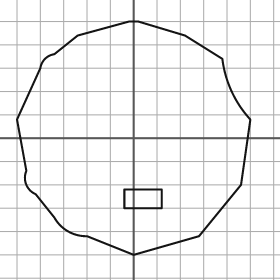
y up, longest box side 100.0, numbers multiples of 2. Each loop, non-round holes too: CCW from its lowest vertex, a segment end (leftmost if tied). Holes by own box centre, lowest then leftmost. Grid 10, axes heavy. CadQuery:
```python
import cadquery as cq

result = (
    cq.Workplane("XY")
    .moveTo(0.0, -50.0)
    .lineTo(28.0, -42.0)
    .lineTo(46.0, -20.0)
    .lineTo(50.0, 8.0)
    .threePointArc((42.0, 20.0), (38.0, 34.0))
    .lineTo(22.0, 44.0)
    .lineTo(2.0, 50.0)
    .lineTo(-2.0, 50.0)
    .lineTo(-24.0, 44.0)
    .lineTo(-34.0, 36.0)
    .threePointArc((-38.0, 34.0), (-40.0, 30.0))
    .lineTo(-50.0, 8.0)
    .lineTo(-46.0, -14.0)
    .threePointArc((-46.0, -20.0), (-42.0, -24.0))
    .lineTo(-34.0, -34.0)
    .threePointArc((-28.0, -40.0), (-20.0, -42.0))
    .close()
    .moveTo(-4.0, -30.0)
    .lineTo(12.0, -30.0)
    .lineTo(12.0, -22.0)
    .lineTo(-4.0, -22.0)
    .close()
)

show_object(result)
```